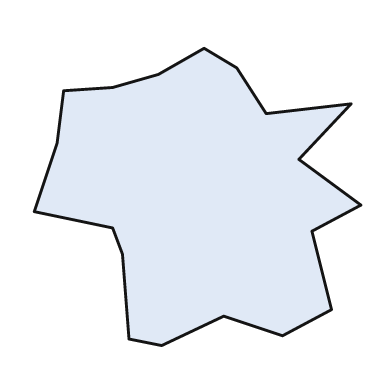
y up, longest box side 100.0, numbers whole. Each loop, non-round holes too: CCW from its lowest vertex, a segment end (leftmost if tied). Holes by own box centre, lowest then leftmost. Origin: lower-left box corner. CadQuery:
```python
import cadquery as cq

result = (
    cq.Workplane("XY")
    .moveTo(39.0, 0.0)
    .lineTo(58.0, 9.0)
    .lineTo(76.0, 3.0)
    .lineTo(91.0, 11.0)
    .lineTo(85.0, 35.0)
    .lineTo(100.0, 43.0)
    .lineTo(81.0, 57.0)
    .lineTo(97.0, 74.0)
    .lineTo(71.0, 71.0)
    .lineTo(62.0, 85.0)
    .lineTo(52.0, 91.0)
    .lineTo(38.0, 83.0)
    .lineTo(24.0, 79.0)
    .lineTo(9.0, 78.0)
    .lineTo(7.0, 62.0)
    .lineTo(0.0, 41.0)
    .lineTo(24.0, 36.0)
    .lineTo(27.0, 28.0)
    .lineTo(29.0, 2.0)
    .close()
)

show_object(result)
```